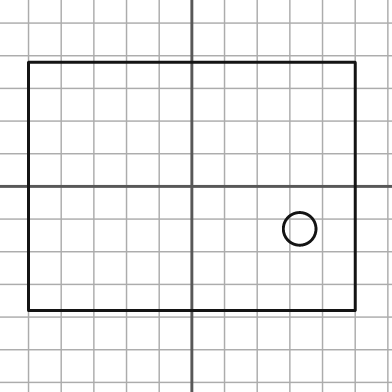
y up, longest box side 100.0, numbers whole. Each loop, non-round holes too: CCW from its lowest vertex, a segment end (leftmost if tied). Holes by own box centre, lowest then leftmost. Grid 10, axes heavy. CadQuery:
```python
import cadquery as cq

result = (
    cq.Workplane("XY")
    .moveTo(-50.0, -38.0)
    .lineTo(50.0, -38.0)
    .lineTo(50.0, 38.0)
    .lineTo(-50.0, 38.0)
    .close()
    .moveTo(33.0, -13.0)
    .circle(5.0)
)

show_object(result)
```